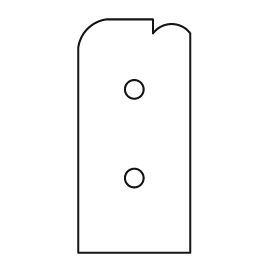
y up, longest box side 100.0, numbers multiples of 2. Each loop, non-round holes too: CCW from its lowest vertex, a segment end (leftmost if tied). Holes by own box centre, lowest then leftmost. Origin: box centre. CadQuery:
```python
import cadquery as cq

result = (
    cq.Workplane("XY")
    .moveTo(-24.0, -50.0)
    .lineTo(24.0, -50.0)
    .lineTo(24.0, 44.0)
    .threePointArc((16.0, 48.0), (8.0, 44.0))
    .lineTo(8.0, 50.0)
    .lineTo(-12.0, 50.0)
    .threePointArc((-20.0, 46.0), (-24.0, 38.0))
    .close()
    .moveTo(0.0, -18.0)
    .circle(4.0)
    .moveTo(0.0, 20.0)
    .circle(4.0)
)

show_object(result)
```